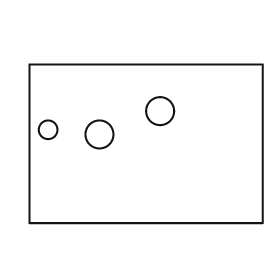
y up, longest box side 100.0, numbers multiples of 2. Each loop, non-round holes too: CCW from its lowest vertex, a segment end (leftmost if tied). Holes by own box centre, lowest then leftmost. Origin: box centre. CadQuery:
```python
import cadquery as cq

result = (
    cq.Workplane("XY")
    .moveTo(-50.0, -34.0)
    .lineTo(50.0, -34.0)
    .lineTo(50.0, 34.0)
    .lineTo(-50.0, 34.0)
    .close()
    .moveTo(-20.0, 4.0)
    .circle(6.0)
    .moveTo(-42.0, 6.0)
    .circle(4.0)
    .moveTo(6.0, 14.0)
    .circle(6.0)
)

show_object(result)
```